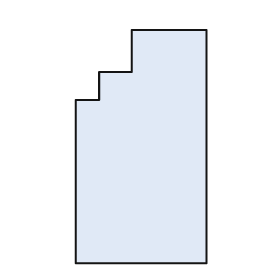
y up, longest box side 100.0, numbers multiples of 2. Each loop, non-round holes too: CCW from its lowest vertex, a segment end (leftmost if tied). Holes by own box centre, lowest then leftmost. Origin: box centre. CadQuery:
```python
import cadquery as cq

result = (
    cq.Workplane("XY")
    .moveTo(-28.0, -50.0)
    .lineTo(28.0, -50.0)
    .lineTo(28.0, 50.0)
    .lineTo(-4.0, 50.0)
    .lineTo(-4.0, 32.0)
    .lineTo(-18.0, 32.0)
    .lineTo(-18.0, 20.0)
    .lineTo(-28.0, 20.0)
    .close()
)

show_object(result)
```